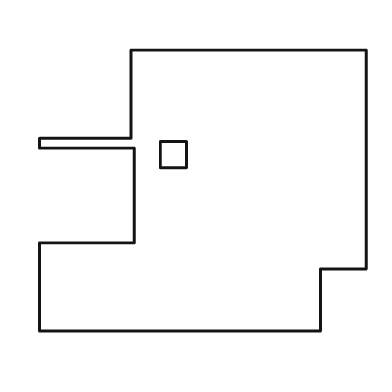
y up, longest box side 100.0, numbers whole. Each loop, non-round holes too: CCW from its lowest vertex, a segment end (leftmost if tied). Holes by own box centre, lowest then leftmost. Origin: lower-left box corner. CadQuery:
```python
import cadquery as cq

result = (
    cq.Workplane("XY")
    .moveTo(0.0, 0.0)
    .lineTo(86.0, 0.0)
    .lineTo(86.0, 19.0)
    .lineTo(100.0, 19.0)
    .lineTo(100.0, 86.0)
    .lineTo(28.0, 86.0)
    .lineTo(28.0, 59.0)
    .lineTo(0.0, 59.0)
    .lineTo(0.0, 56.0)
    .lineTo(29.0, 56.0)
    .lineTo(29.0, 27.0)
    .lineTo(0.0, 27.0)
    .close()
    .moveTo(37.0, 50.0)
    .lineTo(45.0, 50.0)
    .lineTo(45.0, 58.0)
    .lineTo(37.0, 58.0)
    .close()
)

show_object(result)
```